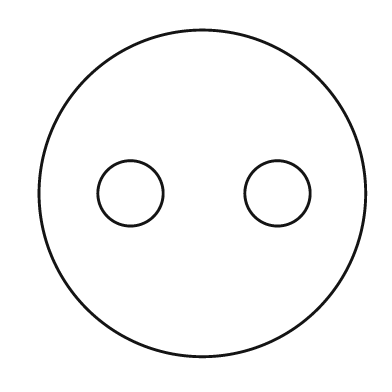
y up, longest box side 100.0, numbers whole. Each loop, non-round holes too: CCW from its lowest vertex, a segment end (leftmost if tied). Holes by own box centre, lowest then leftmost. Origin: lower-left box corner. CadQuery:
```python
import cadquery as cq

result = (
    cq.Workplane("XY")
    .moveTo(50.0, 50.0)
    .circle(50.0)
    .moveTo(28.0, 50.0)
    .circle(10.0)
    .moveTo(73.0, 50.0)
    .circle(10.0)
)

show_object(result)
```